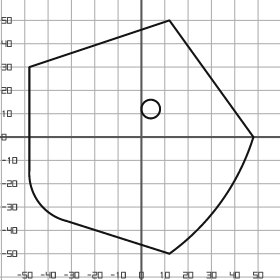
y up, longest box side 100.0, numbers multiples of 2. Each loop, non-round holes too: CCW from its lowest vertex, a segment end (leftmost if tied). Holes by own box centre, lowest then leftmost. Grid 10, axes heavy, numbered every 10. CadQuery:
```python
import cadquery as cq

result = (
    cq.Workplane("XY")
    .moveTo(12.0, -50.0)
    .threePointArc((34.0, -28.0), (48.0, 0.0))
    .lineTo(12.0, 50.0)
    .lineTo(-48.0, 30.0)
    .lineTo(-48.0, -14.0)
    .threePointArc((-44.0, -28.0), (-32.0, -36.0))
    .close()
    .moveTo(4.0, 12.0)
    .circle(4.0)
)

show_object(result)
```